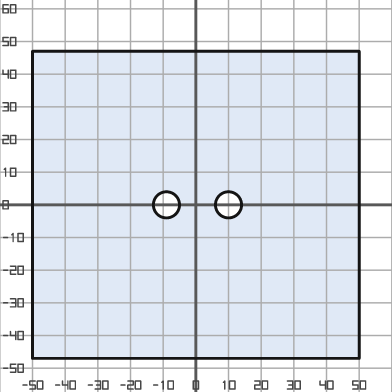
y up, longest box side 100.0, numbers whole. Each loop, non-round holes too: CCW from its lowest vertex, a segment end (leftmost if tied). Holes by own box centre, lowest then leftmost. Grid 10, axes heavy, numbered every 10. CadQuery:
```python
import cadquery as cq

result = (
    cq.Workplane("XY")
    .moveTo(-50.0, -47.0)
    .lineTo(50.0, -47.0)
    .lineTo(50.0, 47.0)
    .lineTo(-50.0, 47.0)
    .close()
    .moveTo(-9.0, 0.0)
    .circle(4.0)
    .moveTo(10.0, 0.0)
    .circle(4.0)
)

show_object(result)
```